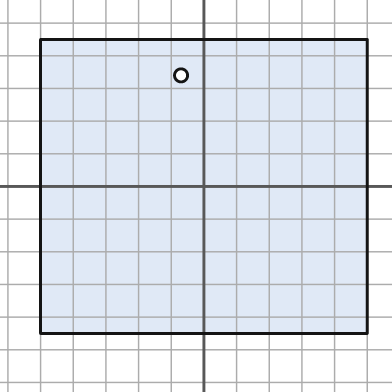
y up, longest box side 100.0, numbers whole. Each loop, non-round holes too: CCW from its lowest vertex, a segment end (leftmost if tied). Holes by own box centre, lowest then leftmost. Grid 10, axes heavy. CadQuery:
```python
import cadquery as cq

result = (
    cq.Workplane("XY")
    .moveTo(-50.0, -45.0)
    .lineTo(50.0, -45.0)
    .lineTo(50.0, 45.0)
    .lineTo(-50.0, 45.0)
    .close()
    .moveTo(-7.0, 34.0)
    .circle(2.0)
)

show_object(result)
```